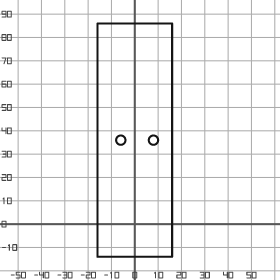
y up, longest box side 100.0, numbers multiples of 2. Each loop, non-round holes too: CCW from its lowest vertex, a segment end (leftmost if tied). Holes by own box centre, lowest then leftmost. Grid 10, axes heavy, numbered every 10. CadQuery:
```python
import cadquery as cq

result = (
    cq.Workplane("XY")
    .moveTo(-16.0, -14.0)
    .lineTo(16.0, -14.0)
    .lineTo(16.0, 86.0)
    .lineTo(-16.0, 86.0)
    .close()
    .moveTo(-6.0, 36.0)
    .circle(2.0)
    .moveTo(8.0, 36.0)
    .circle(2.0)
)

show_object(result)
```